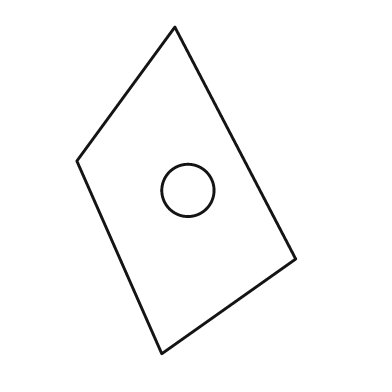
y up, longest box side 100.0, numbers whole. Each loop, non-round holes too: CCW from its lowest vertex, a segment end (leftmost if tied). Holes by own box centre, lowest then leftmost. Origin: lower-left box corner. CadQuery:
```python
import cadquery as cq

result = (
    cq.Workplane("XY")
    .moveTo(26.0, 0.0)
    .lineTo(67.0, 29.0)
    .lineTo(30.0, 100.0)
    .lineTo(0.0, 59.0)
    .close()
    .moveTo(34.0, 50.0)
    .circle(8.0)
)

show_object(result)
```